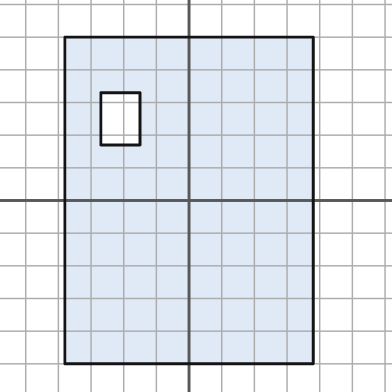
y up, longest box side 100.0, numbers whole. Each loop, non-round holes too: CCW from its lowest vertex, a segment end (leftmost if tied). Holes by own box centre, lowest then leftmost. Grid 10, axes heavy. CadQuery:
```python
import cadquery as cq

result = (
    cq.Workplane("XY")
    .moveTo(-38.0, -50.0)
    .lineTo(38.0, -50.0)
    .lineTo(38.0, 50.0)
    .lineTo(-38.0, 50.0)
    .close()
    .moveTo(-27.0, 17.0)
    .lineTo(-15.0, 17.0)
    .lineTo(-15.0, 33.0)
    .lineTo(-27.0, 33.0)
    .close()
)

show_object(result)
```